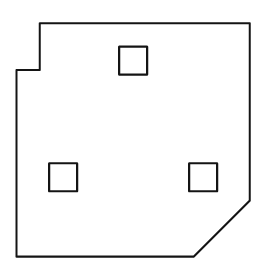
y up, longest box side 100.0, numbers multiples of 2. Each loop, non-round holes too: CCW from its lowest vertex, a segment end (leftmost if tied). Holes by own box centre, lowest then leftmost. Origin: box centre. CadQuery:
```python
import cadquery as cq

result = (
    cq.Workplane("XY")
    .moveTo(-50.0, -50.0)
    .lineTo(26.0, -50.0)
    .lineTo(50.0, -26.0)
    .lineTo(50.0, 50.0)
    .lineTo(-40.0, 50.0)
    .lineTo(-40.0, 30.0)
    .lineTo(-50.0, 30.0)
    .close()
    .moveTo(-36.0, -22.0)
    .lineTo(-24.0, -22.0)
    .lineTo(-24.0, -10.0)
    .lineTo(-36.0, -10.0)
    .close()
    .moveTo(24.0, -22.0)
    .lineTo(36.0, -22.0)
    .lineTo(36.0, -10.0)
    .lineTo(24.0, -10.0)
    .close()
    .moveTo(-6.0, 28.0)
    .lineTo(6.0, 28.0)
    .lineTo(6.0, 40.0)
    .lineTo(-6.0, 40.0)
    .close()
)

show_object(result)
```